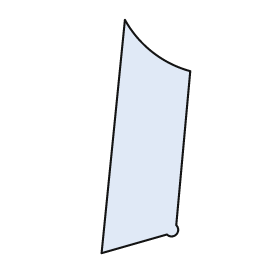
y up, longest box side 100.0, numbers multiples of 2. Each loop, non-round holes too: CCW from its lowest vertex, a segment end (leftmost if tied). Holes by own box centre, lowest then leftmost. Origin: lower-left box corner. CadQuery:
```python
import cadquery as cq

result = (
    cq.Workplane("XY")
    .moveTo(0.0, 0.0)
    .lineTo(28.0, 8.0)
    .threePointArc((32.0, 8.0), (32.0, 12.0))
    .lineTo(38.0, 78.0)
    .threePointArc((22.0, 86.0), (10.0, 100.0))
    .close()
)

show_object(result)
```